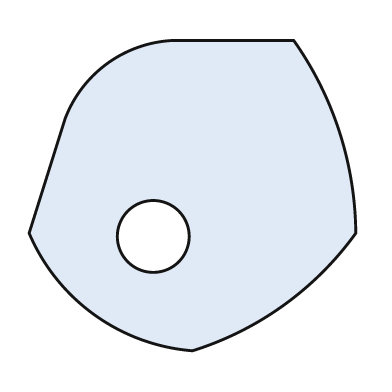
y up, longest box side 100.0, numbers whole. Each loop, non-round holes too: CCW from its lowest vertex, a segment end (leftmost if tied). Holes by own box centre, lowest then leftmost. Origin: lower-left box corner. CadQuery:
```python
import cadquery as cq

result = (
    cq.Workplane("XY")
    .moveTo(50.0, 0.0)
    .threePointArc((78.0, 14.0), (100.0, 36.0))
    .threePointArc((95.0, 67.0), (81.0, 95.0))
    .lineTo(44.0, 95.0)
    .threePointArc((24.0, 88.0), (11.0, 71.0))
    .lineTo(0.0, 36.0)
    .threePointArc((20.0, 11.0), (50.0, 0.0))
    .close()
    .moveTo(38.0, 35.0)
    .circle(11.0)
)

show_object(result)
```